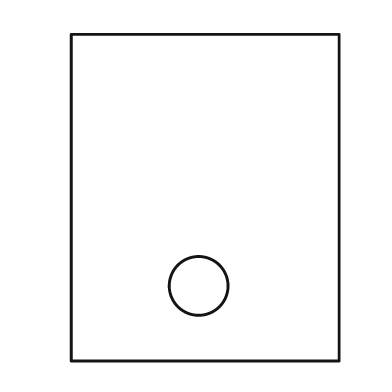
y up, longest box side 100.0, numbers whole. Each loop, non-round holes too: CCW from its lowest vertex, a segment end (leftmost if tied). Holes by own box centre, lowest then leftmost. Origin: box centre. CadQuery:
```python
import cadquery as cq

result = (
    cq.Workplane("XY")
    .moveTo(-41.0, -50.0)
    .lineTo(41.0, -50.0)
    .lineTo(41.0, 50.0)
    .lineTo(-41.0, 50.0)
    .close()
    .moveTo(-2.0, -27.0)
    .circle(9.0)
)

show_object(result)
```